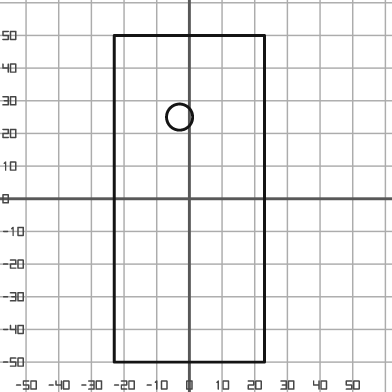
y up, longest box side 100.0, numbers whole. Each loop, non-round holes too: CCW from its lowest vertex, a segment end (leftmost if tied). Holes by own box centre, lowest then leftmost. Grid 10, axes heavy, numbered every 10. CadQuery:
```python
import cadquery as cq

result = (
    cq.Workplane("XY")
    .moveTo(-23.0, -50.0)
    .lineTo(23.0, -50.0)
    .lineTo(23.0, 50.0)
    .lineTo(-23.0, 50.0)
    .close()
    .moveTo(-3.0, 25.0)
    .circle(4.0)
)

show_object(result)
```